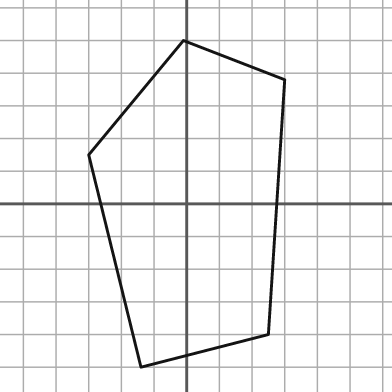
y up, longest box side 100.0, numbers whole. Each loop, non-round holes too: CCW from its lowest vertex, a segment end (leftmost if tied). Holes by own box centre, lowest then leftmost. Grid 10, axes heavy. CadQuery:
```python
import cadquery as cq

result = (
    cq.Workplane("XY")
    .moveTo(-14.0, -50.0)
    .lineTo(25.0, -40.0)
    .lineTo(30.0, 38.0)
    .lineTo(-1.0, 50.0)
    .lineTo(-30.0, 15.0)
    .close()
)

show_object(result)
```